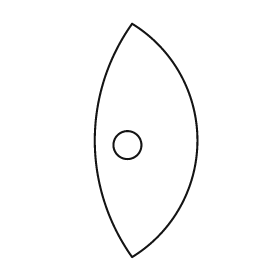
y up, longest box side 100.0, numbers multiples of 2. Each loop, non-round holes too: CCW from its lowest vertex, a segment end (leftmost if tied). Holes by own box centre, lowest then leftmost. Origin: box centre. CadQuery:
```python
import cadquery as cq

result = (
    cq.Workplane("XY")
    .moveTo(-6.0, -50.0)
    .threePointArc((22.0, 0.0), (-6.0, 50.0))
    .threePointArc((-22.0, 0.0), (-6.0, -50.0))
    .close()
    .moveTo(-8.0, -2.0)
    .circle(6.0)
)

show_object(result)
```